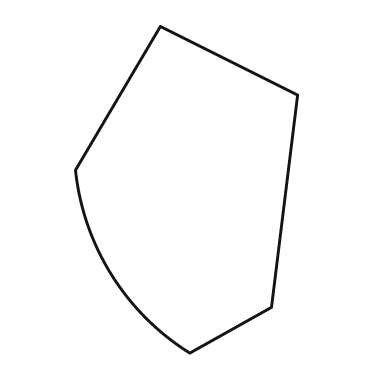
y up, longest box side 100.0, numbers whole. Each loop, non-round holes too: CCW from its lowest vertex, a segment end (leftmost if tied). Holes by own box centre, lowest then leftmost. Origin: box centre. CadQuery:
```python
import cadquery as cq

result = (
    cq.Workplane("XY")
    .moveTo(1.0, -50.0)
    .lineTo(26.0, -36.0)
    .lineTo(34.0, 29.0)
    .lineTo(-8.0, 50.0)
    .lineTo(-34.0, 6.0)
    .threePointArc((-23.0, -26.0), (1.0, -50.0))
    .close()
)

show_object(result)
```